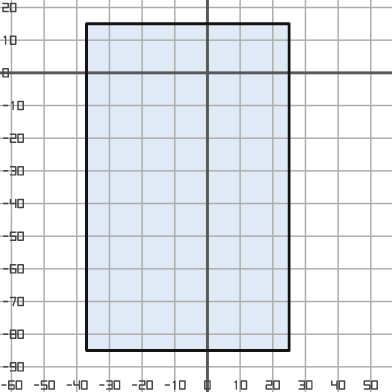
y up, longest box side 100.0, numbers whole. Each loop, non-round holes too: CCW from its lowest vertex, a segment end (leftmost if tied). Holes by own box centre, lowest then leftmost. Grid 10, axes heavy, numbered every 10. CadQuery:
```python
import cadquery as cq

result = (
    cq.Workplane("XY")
    .moveTo(-37.0, -85.0)
    .lineTo(25.0, -85.0)
    .lineTo(25.0, 15.0)
    .lineTo(-37.0, 15.0)
    .close()
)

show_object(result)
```